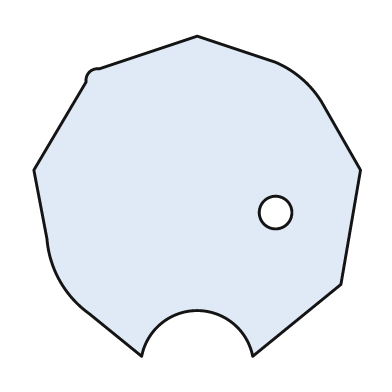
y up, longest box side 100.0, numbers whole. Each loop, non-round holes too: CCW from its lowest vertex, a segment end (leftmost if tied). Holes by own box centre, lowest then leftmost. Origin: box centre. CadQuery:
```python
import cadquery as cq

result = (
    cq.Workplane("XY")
    .moveTo(-17.0, -49.0)
    .threePointArc((0.0, -35.0), (17.0, -49.0))
    .lineTo(44.0, -27.0)
    .lineTo(50.0, 8.0)
    .lineTo(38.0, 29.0)
    .threePointArc((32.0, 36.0), (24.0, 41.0))
    .lineTo(0.0, 49.0)
    .lineTo(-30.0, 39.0)
    .threePointArc((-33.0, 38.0), (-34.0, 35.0))
    .lineTo(-50.0, 8.0)
    .lineTo(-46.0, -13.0)
    .threePointArc((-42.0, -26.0), (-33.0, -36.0))
    .close()
    .moveTo(24.0, -5.0)
    .circle(5.0)
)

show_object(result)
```